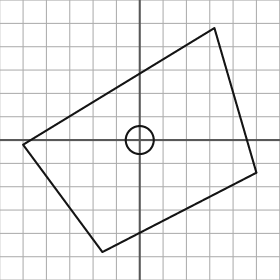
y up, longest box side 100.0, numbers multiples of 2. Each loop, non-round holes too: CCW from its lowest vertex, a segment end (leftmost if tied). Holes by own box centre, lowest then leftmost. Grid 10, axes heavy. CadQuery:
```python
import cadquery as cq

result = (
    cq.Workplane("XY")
    .moveTo(-16.0, -48.0)
    .lineTo(50.0, -14.0)
    .lineTo(32.0, 48.0)
    .lineTo(-50.0, -2.0)
    .close()
    .moveTo(0.0, 0.0)
    .circle(6.0)
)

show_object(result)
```